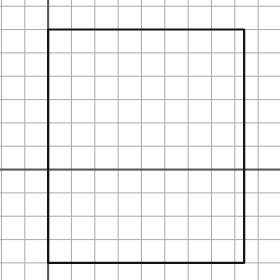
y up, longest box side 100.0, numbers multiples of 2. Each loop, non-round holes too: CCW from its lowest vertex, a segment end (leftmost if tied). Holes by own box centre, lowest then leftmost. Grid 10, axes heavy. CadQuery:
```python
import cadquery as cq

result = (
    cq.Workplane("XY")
    .moveTo(0.0, -40.0)
    .lineTo(84.0, -40.0)
    .lineTo(84.0, 60.0)
    .lineTo(0.0, 60.0)
    .close()
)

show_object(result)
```